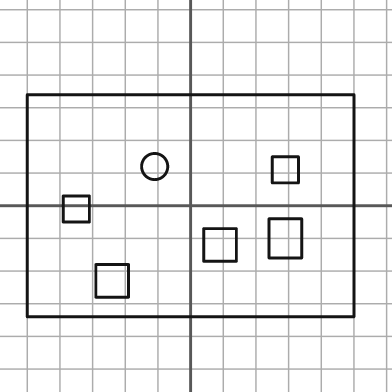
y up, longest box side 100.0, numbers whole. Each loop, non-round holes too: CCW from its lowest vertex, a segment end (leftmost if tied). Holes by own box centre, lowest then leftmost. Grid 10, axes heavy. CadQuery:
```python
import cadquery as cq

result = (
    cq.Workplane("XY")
    .moveTo(-50.0, -34.0)
    .lineTo(50.0, -34.0)
    .lineTo(50.0, 34.0)
    .lineTo(-50.0, 34.0)
    .close()
    .moveTo(-29.0, -28.0)
    .lineTo(-19.0, -28.0)
    .lineTo(-19.0, -18.0)
    .lineTo(-29.0, -18.0)
    .close()
    .moveTo(4.0, -17.0)
    .lineTo(14.0, -17.0)
    .lineTo(14.0, -7.0)
    .lineTo(4.0, -7.0)
    .close()
    .moveTo(24.0, -16.0)
    .lineTo(34.0, -16.0)
    .lineTo(34.0, -4.0)
    .lineTo(24.0, -4.0)
    .close()
    .moveTo(-39.0, -5.0)
    .lineTo(-31.0, -5.0)
    .lineTo(-31.0, 3.0)
    .lineTo(-39.0, 3.0)
    .close()
    .moveTo(25.0, 7.0)
    .lineTo(33.0, 7.0)
    .lineTo(33.0, 15.0)
    .lineTo(25.0, 15.0)
    .close()
    .moveTo(-11.0, 12.0)
    .circle(4.0)
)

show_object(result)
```